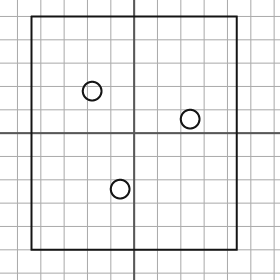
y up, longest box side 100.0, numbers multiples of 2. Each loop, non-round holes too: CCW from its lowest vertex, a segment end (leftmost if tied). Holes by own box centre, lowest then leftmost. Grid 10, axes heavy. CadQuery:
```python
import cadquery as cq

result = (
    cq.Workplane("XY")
    .moveTo(-44.0, -50.0)
    .lineTo(44.0, -50.0)
    .lineTo(44.0, 50.0)
    .lineTo(-44.0, 50.0)
    .close()
    .moveTo(-6.0, -24.0)
    .circle(4.0)
    .moveTo(24.0, 6.0)
    .circle(4.0)
    .moveTo(-18.0, 18.0)
    .circle(4.0)
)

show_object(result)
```